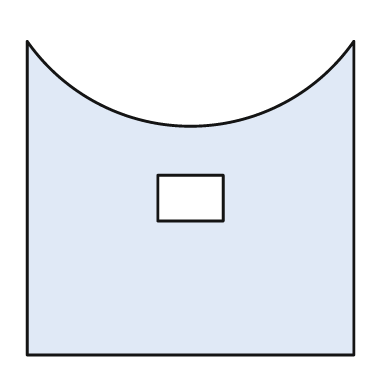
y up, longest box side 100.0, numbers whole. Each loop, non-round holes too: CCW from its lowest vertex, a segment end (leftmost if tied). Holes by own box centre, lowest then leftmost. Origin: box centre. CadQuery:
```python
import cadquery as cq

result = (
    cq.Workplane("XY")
    .moveTo(-50.0, -48.0)
    .lineTo(50.0, -48.0)
    .lineTo(50.0, 48.0)
    .threePointArc((0.0, 22.0), (-50.0, 48.0))
    .close()
    .moveTo(-10.0, -7.0)
    .lineTo(10.0, -7.0)
    .lineTo(10.0, 7.0)
    .lineTo(-10.0, 7.0)
    .close()
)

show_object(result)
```